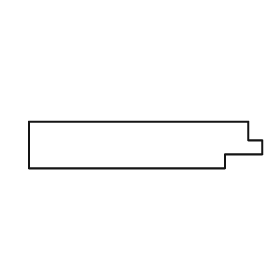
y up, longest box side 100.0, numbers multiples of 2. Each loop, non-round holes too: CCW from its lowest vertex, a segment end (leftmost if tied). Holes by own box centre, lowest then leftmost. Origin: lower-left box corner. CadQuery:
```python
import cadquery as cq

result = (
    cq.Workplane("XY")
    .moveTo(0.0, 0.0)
    .lineTo(84.0, 0.0)
    .lineTo(84.0, 6.0)
    .lineTo(100.0, 6.0)
    .lineTo(100.0, 12.0)
    .lineTo(94.0, 12.0)
    .lineTo(94.0, 20.0)
    .lineTo(0.0, 20.0)
    .close()
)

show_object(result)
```